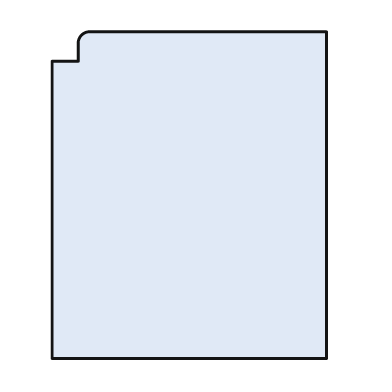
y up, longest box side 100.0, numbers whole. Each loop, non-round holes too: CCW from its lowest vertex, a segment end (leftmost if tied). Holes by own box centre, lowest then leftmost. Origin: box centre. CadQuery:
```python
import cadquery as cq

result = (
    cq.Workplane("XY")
    .moveTo(-42.0, -50.0)
    .lineTo(42.0, -50.0)
    .lineTo(42.0, 50.0)
    .lineTo(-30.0, 50.0)
    .threePointArc((-33.0, 49.0), (-34.0, 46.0))
    .lineTo(-34.0, 41.0)
    .lineTo(-42.0, 41.0)
    .close()
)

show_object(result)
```